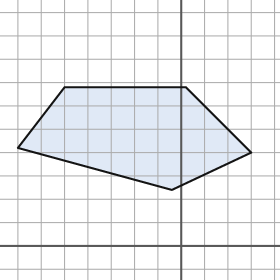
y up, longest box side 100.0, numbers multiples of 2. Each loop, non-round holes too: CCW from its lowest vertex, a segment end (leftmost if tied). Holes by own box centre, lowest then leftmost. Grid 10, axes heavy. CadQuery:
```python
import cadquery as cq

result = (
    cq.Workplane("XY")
    .moveTo(-4.0, 24.0)
    .lineTo(30.0, 40.0)
    .lineTo(2.0, 68.0)
    .lineTo(-50.0, 68.0)
    .lineTo(-70.0, 42.0)
    .close()
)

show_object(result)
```